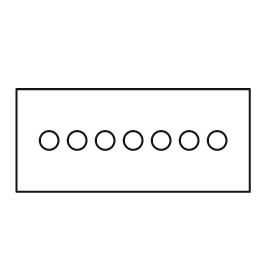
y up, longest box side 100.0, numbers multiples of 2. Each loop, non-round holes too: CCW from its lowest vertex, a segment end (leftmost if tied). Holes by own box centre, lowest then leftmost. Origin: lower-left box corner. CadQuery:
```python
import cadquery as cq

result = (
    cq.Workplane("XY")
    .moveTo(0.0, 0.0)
    .lineTo(100.0, 0.0)
    .lineTo(100.0, 44.0)
    .lineTo(0.0, 44.0)
    .close()
    .moveTo(14.0, 22.0)
    .circle(4.0)
    .moveTo(26.0, 22.0)
    .circle(4.0)
    .moveTo(38.0, 22.0)
    .circle(4.0)
    .moveTo(50.0, 22.0)
    .circle(4.0)
    .moveTo(62.0, 22.0)
    .circle(4.0)
    .moveTo(74.0, 22.0)
    .circle(4.0)
    .moveTo(86.0, 22.0)
    .circle(4.0)
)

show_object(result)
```